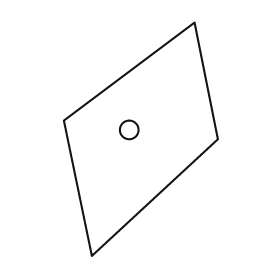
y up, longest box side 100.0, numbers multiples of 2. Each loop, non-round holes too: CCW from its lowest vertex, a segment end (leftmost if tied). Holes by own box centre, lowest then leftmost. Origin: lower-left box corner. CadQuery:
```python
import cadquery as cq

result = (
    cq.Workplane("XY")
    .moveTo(12.0, 0.0)
    .lineTo(66.0, 50.0)
    .lineTo(56.0, 100.0)
    .lineTo(0.0, 58.0)
    .close()
    .moveTo(28.0, 54.0)
    .circle(4.0)
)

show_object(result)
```